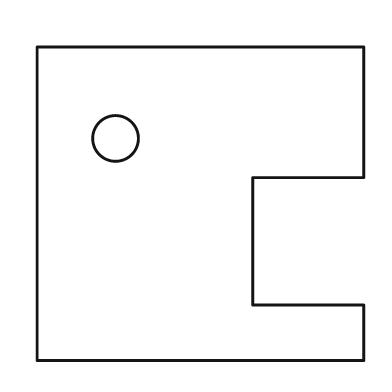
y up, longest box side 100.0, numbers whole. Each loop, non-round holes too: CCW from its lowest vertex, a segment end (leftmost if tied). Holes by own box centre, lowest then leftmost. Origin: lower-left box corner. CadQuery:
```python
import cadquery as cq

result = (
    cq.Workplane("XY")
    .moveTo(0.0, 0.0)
    .lineTo(100.0, 0.0)
    .lineTo(100.0, 17.0)
    .lineTo(66.0, 17.0)
    .lineTo(66.0, 56.0)
    .lineTo(100.0, 56.0)
    .lineTo(100.0, 96.0)
    .lineTo(0.0, 96.0)
    .close()
    .moveTo(24.0, 68.0)
    .circle(7.0)
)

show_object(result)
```